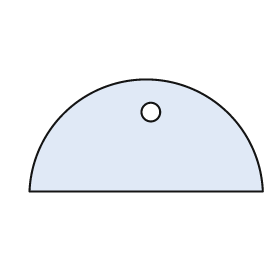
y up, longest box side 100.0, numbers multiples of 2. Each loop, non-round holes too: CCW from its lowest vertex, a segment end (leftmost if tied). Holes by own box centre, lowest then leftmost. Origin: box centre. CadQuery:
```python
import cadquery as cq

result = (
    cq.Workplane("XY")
    .moveTo(-50.0, -24.0)
    .lineTo(50.0, -24.0)
    .threePointArc((0.0, 24.0), (-50.0, -24.0))
    .close()
    .moveTo(2.0, 10.0)
    .circle(4.0)
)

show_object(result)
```